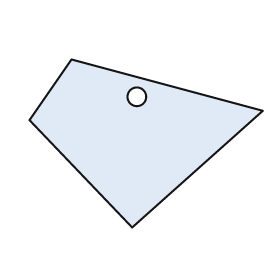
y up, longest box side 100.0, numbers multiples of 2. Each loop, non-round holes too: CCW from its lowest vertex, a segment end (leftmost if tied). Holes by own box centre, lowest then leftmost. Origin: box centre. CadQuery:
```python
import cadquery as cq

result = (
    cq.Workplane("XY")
    .moveTo(-6.0, -36.0)
    .lineTo(50.0, 14.0)
    .lineTo(-32.0, 36.0)
    .lineTo(-50.0, 10.0)
    .close()
    .moveTo(-4.0, 20.0)
    .circle(4.0)
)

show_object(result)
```